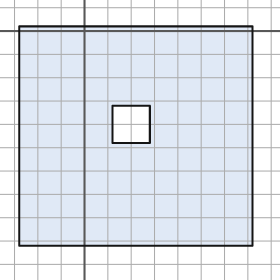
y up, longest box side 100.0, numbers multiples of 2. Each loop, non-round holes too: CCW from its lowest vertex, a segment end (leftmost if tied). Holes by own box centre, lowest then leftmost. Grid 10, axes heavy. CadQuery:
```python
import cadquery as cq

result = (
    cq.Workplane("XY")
    .moveTo(-28.0, -92.0)
    .lineTo(72.0, -92.0)
    .lineTo(72.0, 2.0)
    .lineTo(-28.0, 2.0)
    .close()
    .moveTo(12.0, -48.0)
    .lineTo(28.0, -48.0)
    .lineTo(28.0, -32.0)
    .lineTo(12.0, -32.0)
    .close()
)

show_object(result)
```